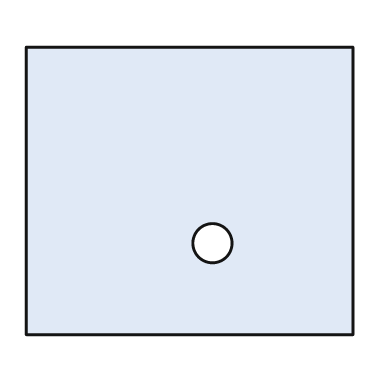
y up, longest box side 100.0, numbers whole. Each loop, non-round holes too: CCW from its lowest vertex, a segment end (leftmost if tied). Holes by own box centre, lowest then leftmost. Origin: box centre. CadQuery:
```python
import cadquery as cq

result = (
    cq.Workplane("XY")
    .moveTo(-50.0, -44.0)
    .lineTo(50.0, -44.0)
    .lineTo(50.0, 44.0)
    .lineTo(-50.0, 44.0)
    .close()
    .moveTo(7.0, -16.0)
    .circle(6.0)
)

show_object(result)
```